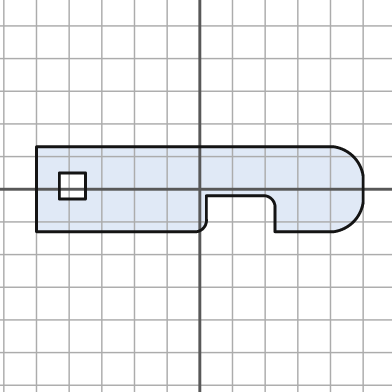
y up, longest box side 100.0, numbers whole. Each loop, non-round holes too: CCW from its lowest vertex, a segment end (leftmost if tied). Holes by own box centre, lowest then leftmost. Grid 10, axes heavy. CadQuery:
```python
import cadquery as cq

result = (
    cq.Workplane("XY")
    .moveTo(-50.0, -13.0)
    .lineTo(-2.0, -13.0)
    .threePointArc((1.0, -12.0), (2.0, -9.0))
    .lineTo(2.0, -2.0)
    .lineTo(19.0, -2.0)
    .threePointArc((22.0, -3.0), (23.0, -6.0))
    .lineTo(23.0, -13.0)
    .lineTo(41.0, -13.0)
    .threePointArc((47.0, -10.0), (50.0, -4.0))
    .lineTo(50.0, 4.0)
    .threePointArc((47.0, 10.0), (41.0, 13.0))
    .lineTo(-50.0, 13.0)
    .close()
    .moveTo(-43.0, -3.0)
    .lineTo(-35.0, -3.0)
    .lineTo(-35.0, 5.0)
    .lineTo(-43.0, 5.0)
    .close()
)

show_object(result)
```